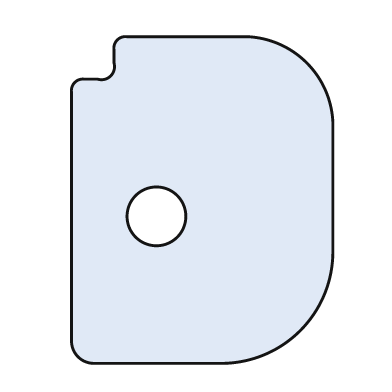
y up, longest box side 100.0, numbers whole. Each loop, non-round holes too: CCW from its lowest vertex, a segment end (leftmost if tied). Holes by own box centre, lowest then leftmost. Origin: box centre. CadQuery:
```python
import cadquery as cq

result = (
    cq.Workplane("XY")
    .moveTo(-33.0, -50.0)
    .lineTo(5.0, -50.0)
    .threePointArc((30.0, -40.0), (40.0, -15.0))
    .lineTo(40.0, 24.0)
    .threePointArc((32.0, 42.0), (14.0, 50.0))
    .lineTo(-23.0, 50.0)
    .threePointArc((-26.0, 49.0), (-27.0, 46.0))
    .lineTo(-27.0, 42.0)
    .threePointArc((-28.0, 38.0), (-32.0, 37.0))
    .lineTo(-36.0, 37.0)
    .threePointArc((-39.0, 36.0), (-40.0, 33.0))
    .lineTo(-40.0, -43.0)
    .threePointArc((-38.0, -48.0), (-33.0, -50.0))
    .close()
    .moveTo(-14.0, -5.0)
    .circle(9.0)
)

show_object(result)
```